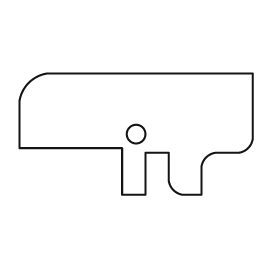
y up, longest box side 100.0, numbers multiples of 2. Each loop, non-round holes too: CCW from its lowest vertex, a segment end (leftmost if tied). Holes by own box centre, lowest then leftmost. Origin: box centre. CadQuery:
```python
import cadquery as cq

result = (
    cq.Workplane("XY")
    .moveTo(-6.0, -26.0)
    .lineTo(4.0, -26.0)
    .lineTo(4.0, -8.0)
    .lineTo(14.0, -8.0)
    .lineTo(14.0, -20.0)
    .threePointArc((16.0, -24.0), (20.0, -26.0))
    .lineTo(28.0, -26.0)
    .lineTo(28.0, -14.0)
    .threePointArc((30.0, -10.0), (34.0, -8.0))
    .lineTo(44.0, -8.0)
    .threePointArc((48.0, -6.0), (50.0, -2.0))
    .lineTo(50.0, 26.0)
    .lineTo(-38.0, 26.0)
    .threePointArc((-46.0, 22.0), (-50.0, 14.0))
    .lineTo(-50.0, -6.0)
    .lineTo(-6.0, -6.0)
    .close()
    .moveTo(0.0, 0.0)
    .circle(4.0)
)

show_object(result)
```